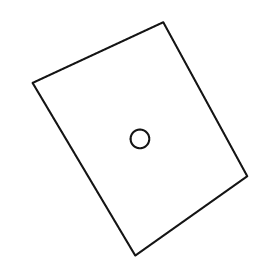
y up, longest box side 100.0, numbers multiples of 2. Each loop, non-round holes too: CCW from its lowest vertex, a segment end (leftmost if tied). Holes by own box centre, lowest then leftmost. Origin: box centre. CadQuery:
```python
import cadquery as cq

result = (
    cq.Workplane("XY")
    .moveTo(-2.0, -50.0)
    .lineTo(46.0, -16.0)
    .lineTo(10.0, 50.0)
    .lineTo(-46.0, 24.0)
    .close()
    .moveTo(0.0, 0.0)
    .circle(4.0)
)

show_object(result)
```